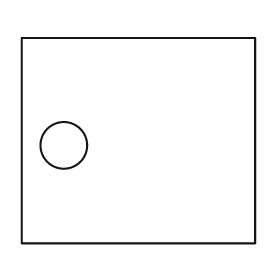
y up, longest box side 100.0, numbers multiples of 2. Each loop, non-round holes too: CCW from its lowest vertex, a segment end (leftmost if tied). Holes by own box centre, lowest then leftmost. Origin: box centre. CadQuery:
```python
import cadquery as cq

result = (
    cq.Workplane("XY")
    .moveTo(-50.0, -44.0)
    .lineTo(50.0, -44.0)
    .lineTo(50.0, 44.0)
    .lineTo(-50.0, 44.0)
    .close()
    .moveTo(-32.0, -2.0)
    .circle(10.0)
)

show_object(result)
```